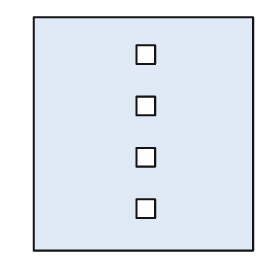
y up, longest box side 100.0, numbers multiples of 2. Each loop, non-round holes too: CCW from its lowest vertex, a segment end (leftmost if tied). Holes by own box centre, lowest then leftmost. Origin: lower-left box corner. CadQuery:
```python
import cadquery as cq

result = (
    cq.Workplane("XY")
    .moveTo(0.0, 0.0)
    .lineTo(94.0, 0.0)
    .lineTo(94.0, 100.0)
    .lineTo(0.0, 100.0)
    .close()
    .moveTo(44.0, 14.0)
    .lineTo(52.0, 14.0)
    .lineTo(52.0, 22.0)
    .lineTo(44.0, 22.0)
    .close()
    .moveTo(44.0, 36.0)
    .lineTo(52.0, 36.0)
    .lineTo(52.0, 44.0)
    .lineTo(44.0, 44.0)
    .close()
    .moveTo(44.0, 58.0)
    .lineTo(52.0, 58.0)
    .lineTo(52.0, 66.0)
    .lineTo(44.0, 66.0)
    .close()
    .moveTo(44.0, 80.0)
    .lineTo(52.0, 80.0)
    .lineTo(52.0, 88.0)
    .lineTo(44.0, 88.0)
    .close()
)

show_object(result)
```